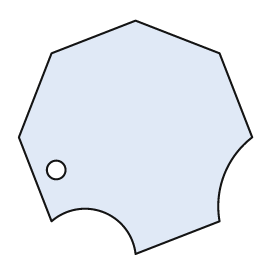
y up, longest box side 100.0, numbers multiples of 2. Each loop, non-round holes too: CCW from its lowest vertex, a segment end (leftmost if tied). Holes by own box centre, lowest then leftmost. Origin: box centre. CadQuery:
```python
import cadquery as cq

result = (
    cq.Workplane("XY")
    .moveTo(0.0, -50.0)
    .lineTo(36.0, -36.0)
    .threePointArc((38.0, -16.0), (50.0, 0.0))
    .lineTo(36.0, 36.0)
    .lineTo(0.0, 50.0)
    .lineTo(-36.0, 36.0)
    .lineTo(-50.0, 0.0)
    .lineTo(-36.0, -36.0)
    .threePointArc((-14.0, -32.0), (0.0, -50.0))
    .close()
    .moveTo(-34.0, -14.0)
    .circle(4.0)
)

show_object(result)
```